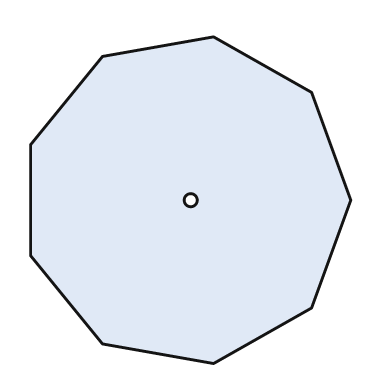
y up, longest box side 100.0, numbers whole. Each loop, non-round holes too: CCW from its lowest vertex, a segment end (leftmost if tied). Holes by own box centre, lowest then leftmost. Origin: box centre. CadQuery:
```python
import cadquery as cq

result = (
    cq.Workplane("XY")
    .moveTo(7.0, -50.0)
    .lineTo(37.0, -33.0)
    .lineTo(49.0, 0.0)
    .lineTo(37.0, 33.0)
    .lineTo(7.0, 50.0)
    .lineTo(-27.0, 44.0)
    .lineTo(-49.0, 17.0)
    .lineTo(-49.0, -17.0)
    .lineTo(-27.0, -44.0)
    .close()
    .moveTo(0.0, 0.0)
    .circle(2.0)
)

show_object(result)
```